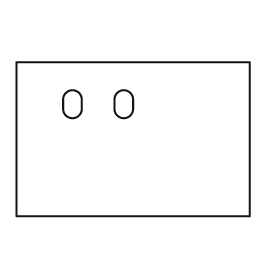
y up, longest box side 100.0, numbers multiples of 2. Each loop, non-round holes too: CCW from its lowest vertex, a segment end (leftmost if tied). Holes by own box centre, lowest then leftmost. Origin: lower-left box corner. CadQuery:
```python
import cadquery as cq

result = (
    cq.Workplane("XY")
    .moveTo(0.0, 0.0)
    .lineTo(100.0, 0.0)
    .lineTo(100.0, 66.0)
    .lineTo(0.0, 66.0)
    .close()
    .moveTo(20.0, 46.0)
    .threePointArc((24.0, 42.0), (28.0, 46.0))
    .lineTo(28.0, 50.0)
    .threePointArc((24.0, 54.0), (20.0, 50.0))
    .close()
    .moveTo(42.0, 46.0)
    .threePointArc((46.0, 42.0), (50.0, 46.0))
    .lineTo(50.0, 50.0)
    .threePointArc((46.0, 54.0), (42.0, 50.0))
    .close()
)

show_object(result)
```